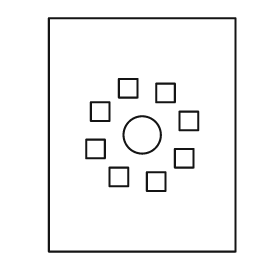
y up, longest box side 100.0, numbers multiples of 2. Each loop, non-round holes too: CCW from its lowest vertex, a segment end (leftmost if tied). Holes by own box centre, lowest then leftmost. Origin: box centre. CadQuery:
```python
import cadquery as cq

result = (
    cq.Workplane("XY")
    .moveTo(-40.0, -50.0)
    .lineTo(40.0, -50.0)
    .lineTo(40.0, 50.0)
    .lineTo(-40.0, 50.0)
    .close()
    .moveTo(2.0, -24.0)
    .lineTo(10.0, -24.0)
    .lineTo(10.0, -16.0)
    .lineTo(2.0, -16.0)
    .close()
    .moveTo(-14.0, -22.0)
    .lineTo(-6.0, -22.0)
    .lineTo(-6.0, -14.0)
    .lineTo(-14.0, -14.0)
    .close()
    .moveTo(14.0, -14.0)
    .lineTo(22.0, -14.0)
    .lineTo(22.0, -6.0)
    .lineTo(14.0, -6.0)
    .close()
    .moveTo(-24.0, -10.0)
    .lineTo(-16.0, -10.0)
    .lineTo(-16.0, -2.0)
    .lineTo(-24.0, -2.0)
    .close()
    .moveTo(0.0, 0.0)
    .circle(8.0)
    .moveTo(16.0, 2.0)
    .lineTo(24.0, 2.0)
    .lineTo(24.0, 10.0)
    .lineTo(16.0, 10.0)
    .close()
    .moveTo(-22.0, 6.0)
    .lineTo(-14.0, 6.0)
    .lineTo(-14.0, 14.0)
    .lineTo(-22.0, 14.0)
    .close()
    .moveTo(6.0, 14.0)
    .lineTo(14.0, 14.0)
    .lineTo(14.0, 22.0)
    .lineTo(6.0, 22.0)
    .close()
    .moveTo(-10.0, 16.0)
    .lineTo(-2.0, 16.0)
    .lineTo(-2.0, 24.0)
    .lineTo(-10.0, 24.0)
    .close()
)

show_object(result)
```